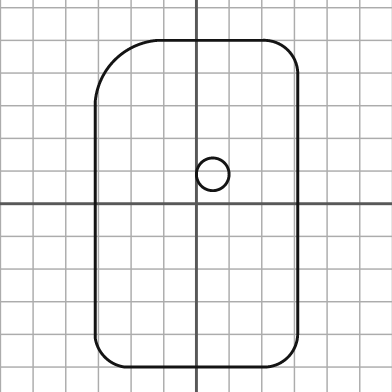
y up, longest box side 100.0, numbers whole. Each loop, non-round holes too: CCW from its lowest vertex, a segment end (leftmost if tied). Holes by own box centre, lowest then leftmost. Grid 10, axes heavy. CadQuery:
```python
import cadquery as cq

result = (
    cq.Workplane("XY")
    .moveTo(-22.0, -50.0)
    .lineTo(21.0, -50.0)
    .threePointArc((28.0, -47.0), (31.0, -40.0))
    .lineTo(31.0, 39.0)
    .threePointArc((28.0, 47.0), (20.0, 50.0))
    .lineTo(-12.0, 50.0)
    .threePointArc((-25.0, 44.0), (-31.0, 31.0))
    .lineTo(-31.0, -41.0)
    .threePointArc((-28.0, -47.0), (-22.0, -50.0))
    .close()
    .moveTo(5.0, 9.0)
    .circle(5.0)
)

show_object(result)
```